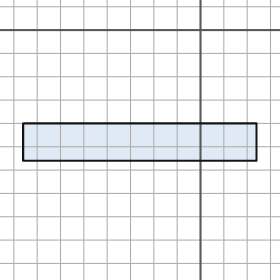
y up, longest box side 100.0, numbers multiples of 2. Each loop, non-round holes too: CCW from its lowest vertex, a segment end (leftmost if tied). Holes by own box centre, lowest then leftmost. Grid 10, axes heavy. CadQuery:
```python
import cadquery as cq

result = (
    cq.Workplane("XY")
    .moveTo(-76.0, -56.0)
    .lineTo(24.0, -56.0)
    .lineTo(24.0, -40.0)
    .lineTo(-76.0, -40.0)
    .close()
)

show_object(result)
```